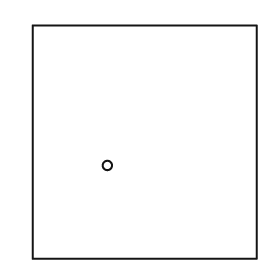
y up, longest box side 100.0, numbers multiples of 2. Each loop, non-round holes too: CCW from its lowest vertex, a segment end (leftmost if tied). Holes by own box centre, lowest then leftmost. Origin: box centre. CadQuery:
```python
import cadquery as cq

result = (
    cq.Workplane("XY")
    .moveTo(-48.0, -50.0)
    .lineTo(48.0, -50.0)
    .lineTo(48.0, 50.0)
    .lineTo(-48.0, 50.0)
    .close()
    .moveTo(-16.0, -10.0)
    .circle(2.0)
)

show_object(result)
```